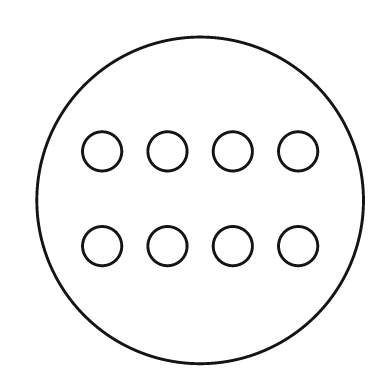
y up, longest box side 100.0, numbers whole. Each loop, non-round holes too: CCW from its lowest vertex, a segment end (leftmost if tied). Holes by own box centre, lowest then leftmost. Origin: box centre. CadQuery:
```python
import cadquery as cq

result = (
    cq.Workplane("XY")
    .moveTo(0.0, 0.0)
    .circle(50.0)
    .moveTo(-30.0, -14.0)
    .circle(6.0)
    .moveTo(-10.0, -14.0)
    .circle(6.0)
    .moveTo(10.0, -14.0)
    .circle(6.0)
    .moveTo(30.0, -14.0)
    .circle(6.0)
    .moveTo(-30.0, 15.0)
    .circle(6.0)
    .moveTo(-10.0, 15.0)
    .circle(6.0)
    .moveTo(10.0, 15.0)
    .circle(6.0)
    .moveTo(30.0, 15.0)
    .circle(6.0)
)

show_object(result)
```